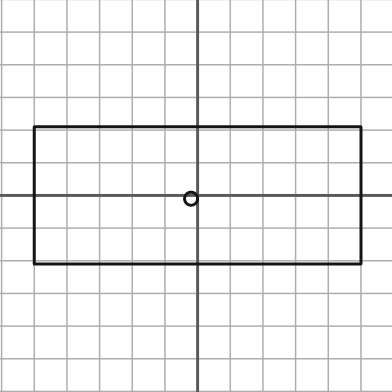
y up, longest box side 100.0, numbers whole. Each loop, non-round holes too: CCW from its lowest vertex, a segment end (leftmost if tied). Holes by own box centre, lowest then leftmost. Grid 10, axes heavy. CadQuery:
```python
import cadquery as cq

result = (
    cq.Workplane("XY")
    .moveTo(-50.0, -21.0)
    .lineTo(50.0, -21.0)
    .lineTo(50.0, 21.0)
    .lineTo(-50.0, 21.0)
    .close()
    .moveTo(-2.0, -1.0)
    .circle(2.0)
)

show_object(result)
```